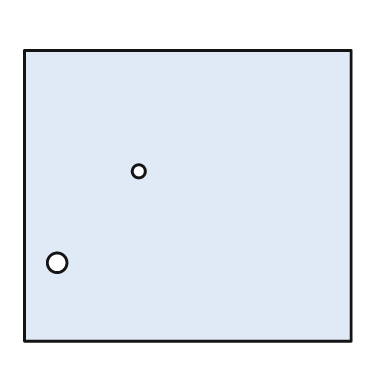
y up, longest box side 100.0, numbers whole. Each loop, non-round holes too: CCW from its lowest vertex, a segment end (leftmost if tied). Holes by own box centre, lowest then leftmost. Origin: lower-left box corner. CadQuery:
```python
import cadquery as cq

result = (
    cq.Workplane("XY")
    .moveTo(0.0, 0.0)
    .lineTo(100.0, 0.0)
    .lineTo(100.0, 89.0)
    .lineTo(0.0, 89.0)
    .close()
    .moveTo(10.0, 24.0)
    .circle(3.0)
    .moveTo(35.0, 52.0)
    .circle(2.0)
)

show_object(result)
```